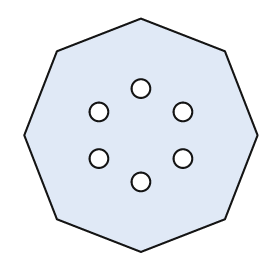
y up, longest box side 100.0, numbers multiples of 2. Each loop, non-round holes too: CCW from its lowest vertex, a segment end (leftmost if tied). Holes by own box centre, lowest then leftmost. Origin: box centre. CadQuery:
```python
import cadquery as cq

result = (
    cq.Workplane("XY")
    .moveTo(0.0, -50.0)
    .lineTo(36.0, -36.0)
    .lineTo(50.0, 0.0)
    .lineTo(36.0, 36.0)
    .lineTo(0.0, 50.0)
    .lineTo(-36.0, 36.0)
    .lineTo(-50.0, 0.0)
    .lineTo(-36.0, -36.0)
    .close()
    .moveTo(0.0, -20.0)
    .circle(4.0)
    .moveTo(-18.0, -10.0)
    .circle(4.0)
    .moveTo(18.0, -10.0)
    .circle(4.0)
    .moveTo(-18.0, 10.0)
    .circle(4.0)
    .moveTo(18.0, 10.0)
    .circle(4.0)
    .moveTo(0.0, 20.0)
    .circle(4.0)
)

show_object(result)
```